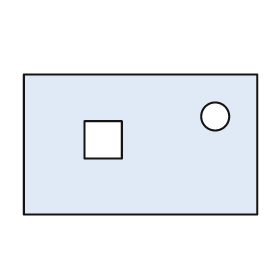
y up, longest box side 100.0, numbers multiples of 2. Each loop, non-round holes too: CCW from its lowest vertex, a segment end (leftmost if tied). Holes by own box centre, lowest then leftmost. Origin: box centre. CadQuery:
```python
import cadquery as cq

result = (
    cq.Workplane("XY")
    .moveTo(-50.0, -30.0)
    .lineTo(50.0, -30.0)
    .lineTo(50.0, 30.0)
    .lineTo(-50.0, 30.0)
    .close()
    .moveTo(-24.0, -6.0)
    .lineTo(-8.0, -6.0)
    .lineTo(-8.0, 10.0)
    .lineTo(-24.0, 10.0)
    .close()
    .moveTo(32.0, 12.0)
    .circle(6.0)
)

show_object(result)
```